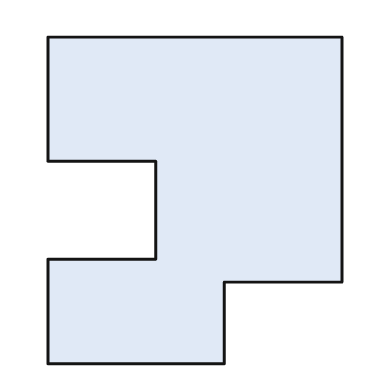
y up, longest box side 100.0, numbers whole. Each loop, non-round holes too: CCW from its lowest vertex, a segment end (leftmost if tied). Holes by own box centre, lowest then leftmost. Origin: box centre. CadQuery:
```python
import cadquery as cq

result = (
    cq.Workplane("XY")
    .moveTo(-45.0, -50.0)
    .lineTo(9.0, -50.0)
    .lineTo(9.0, -25.0)
    .lineTo(45.0, -25.0)
    .lineTo(45.0, 50.0)
    .lineTo(-45.0, 50.0)
    .lineTo(-45.0, 12.0)
    .lineTo(-12.0, 12.0)
    .lineTo(-12.0, -18.0)
    .lineTo(-45.0, -18.0)
    .close()
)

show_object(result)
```